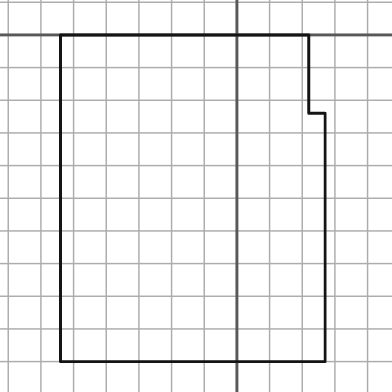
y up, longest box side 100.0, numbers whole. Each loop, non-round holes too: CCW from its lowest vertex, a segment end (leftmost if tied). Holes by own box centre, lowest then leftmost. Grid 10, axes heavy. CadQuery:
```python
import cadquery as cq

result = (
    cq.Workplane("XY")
    .moveTo(-54.0, -100.0)
    .lineTo(27.0, -100.0)
    .lineTo(27.0, -24.0)
    .lineTo(22.0, -24.0)
    .lineTo(22.0, 0.0)
    .lineTo(-54.0, 0.0)
    .close()
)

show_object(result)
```